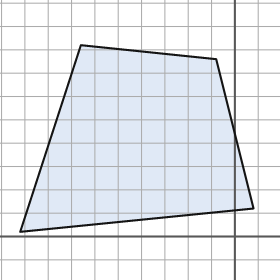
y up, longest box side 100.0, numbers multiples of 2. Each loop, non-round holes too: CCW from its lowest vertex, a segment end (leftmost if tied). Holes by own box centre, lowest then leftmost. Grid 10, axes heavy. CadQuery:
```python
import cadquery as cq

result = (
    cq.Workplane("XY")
    .moveTo(-92.0, 2.0)
    .lineTo(8.0, 12.0)
    .lineTo(-8.0, 76.0)
    .lineTo(-66.0, 82.0)
    .close()
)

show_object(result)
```